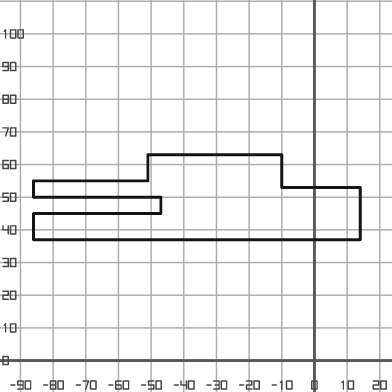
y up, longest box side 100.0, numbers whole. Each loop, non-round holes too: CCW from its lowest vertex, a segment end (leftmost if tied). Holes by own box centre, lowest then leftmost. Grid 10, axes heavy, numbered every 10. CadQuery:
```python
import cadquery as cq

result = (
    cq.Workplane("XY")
    .moveTo(-86.0, 37.0)
    .lineTo(14.0, 37.0)
    .lineTo(14.0, 53.0)
    .lineTo(-10.0, 53.0)
    .lineTo(-10.0, 63.0)
    .lineTo(-51.0, 63.0)
    .lineTo(-51.0, 55.0)
    .lineTo(-86.0, 55.0)
    .lineTo(-86.0, 50.0)
    .lineTo(-47.0, 50.0)
    .lineTo(-47.0, 45.0)
    .lineTo(-86.0, 45.0)
    .close()
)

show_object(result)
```